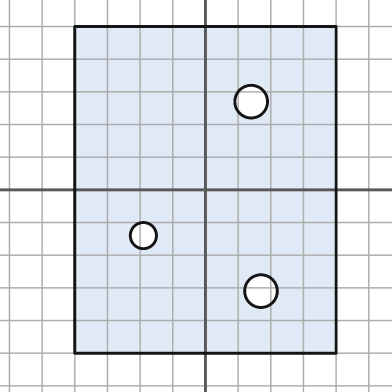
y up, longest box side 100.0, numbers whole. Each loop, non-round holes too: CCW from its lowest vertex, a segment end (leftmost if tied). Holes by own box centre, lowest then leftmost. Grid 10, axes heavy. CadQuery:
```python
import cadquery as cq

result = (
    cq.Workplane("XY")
    .moveTo(-40.0, -50.0)
    .lineTo(40.0, -50.0)
    .lineTo(40.0, 50.0)
    .lineTo(-40.0, 50.0)
    .close()
    .moveTo(17.0, -31.0)
    .circle(5.0)
    .moveTo(-19.0, -14.0)
    .circle(4.0)
    .moveTo(14.0, 27.0)
    .circle(5.0)
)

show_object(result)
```